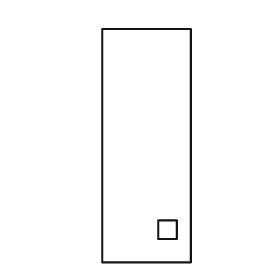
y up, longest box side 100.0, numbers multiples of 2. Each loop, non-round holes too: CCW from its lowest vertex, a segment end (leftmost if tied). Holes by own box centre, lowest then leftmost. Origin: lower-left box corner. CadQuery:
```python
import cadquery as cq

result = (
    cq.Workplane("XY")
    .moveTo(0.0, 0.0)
    .lineTo(38.0, 0.0)
    .lineTo(38.0, 100.0)
    .lineTo(0.0, 100.0)
    .close()
    .moveTo(24.0, 10.0)
    .lineTo(32.0, 10.0)
    .lineTo(32.0, 18.0)
    .lineTo(24.0, 18.0)
    .close()
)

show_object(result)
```